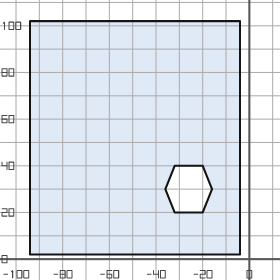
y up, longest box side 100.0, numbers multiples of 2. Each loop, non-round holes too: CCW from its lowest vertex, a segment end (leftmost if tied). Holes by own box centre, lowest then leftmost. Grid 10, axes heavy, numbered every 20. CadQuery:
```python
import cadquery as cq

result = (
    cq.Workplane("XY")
    .moveTo(-94.0, 2.0)
    .lineTo(-4.0, 2.0)
    .lineTo(-4.0, 102.0)
    .lineTo(-94.0, 102.0)
    .close()
    .moveTo(-32.0, 20.0)
    .lineTo(-20.0, 20.0)
    .lineTo(-16.0, 30.0)
    .lineTo(-20.0, 40.0)
    .lineTo(-32.0, 40.0)
    .lineTo(-36.0, 30.0)
    .close()
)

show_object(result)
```